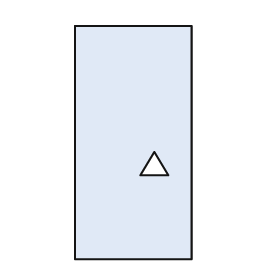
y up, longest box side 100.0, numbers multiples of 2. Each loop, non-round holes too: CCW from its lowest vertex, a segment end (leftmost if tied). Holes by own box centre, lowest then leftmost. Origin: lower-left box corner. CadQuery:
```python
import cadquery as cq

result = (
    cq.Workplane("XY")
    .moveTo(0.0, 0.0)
    .lineTo(50.0, 0.0)
    .lineTo(50.0, 100.0)
    .lineTo(0.0, 100.0)
    .close()
    .moveTo(28.0, 36.0)
    .lineTo(40.0, 36.0)
    .lineTo(34.0, 46.0)
    .close()
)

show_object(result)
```